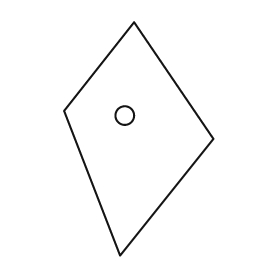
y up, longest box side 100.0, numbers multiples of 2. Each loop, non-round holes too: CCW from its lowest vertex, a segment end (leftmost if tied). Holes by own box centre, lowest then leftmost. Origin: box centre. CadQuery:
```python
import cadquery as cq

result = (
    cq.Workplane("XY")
    .moveTo(-8.0, -50.0)
    .lineTo(32.0, 0.0)
    .lineTo(-2.0, 50.0)
    .lineTo(-32.0, 12.0)
    .close()
    .moveTo(-6.0, 10.0)
    .circle(4.0)
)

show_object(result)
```